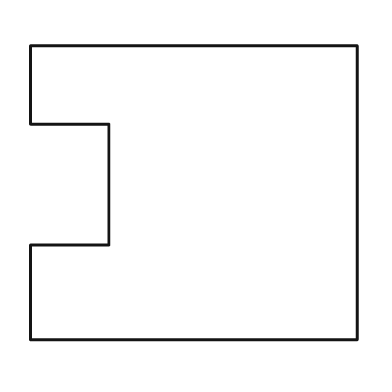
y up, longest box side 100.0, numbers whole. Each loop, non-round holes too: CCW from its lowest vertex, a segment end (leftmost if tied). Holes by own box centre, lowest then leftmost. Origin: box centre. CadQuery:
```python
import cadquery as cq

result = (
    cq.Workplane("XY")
    .moveTo(-50.0, -45.0)
    .lineTo(50.0, -45.0)
    .lineTo(50.0, 45.0)
    .lineTo(-50.0, 45.0)
    .lineTo(-50.0, 21.0)
    .lineTo(-26.0, 21.0)
    .lineTo(-26.0, -16.0)
    .lineTo(-50.0, -16.0)
    .close()
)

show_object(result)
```